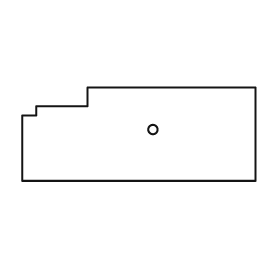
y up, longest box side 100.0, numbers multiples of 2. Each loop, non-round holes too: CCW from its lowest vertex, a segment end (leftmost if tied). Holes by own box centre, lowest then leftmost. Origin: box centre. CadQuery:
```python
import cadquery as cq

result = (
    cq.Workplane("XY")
    .moveTo(-50.0, -20.0)
    .lineTo(50.0, -20.0)
    .lineTo(50.0, 20.0)
    .lineTo(-22.0, 20.0)
    .lineTo(-22.0, 12.0)
    .lineTo(-44.0, 12.0)
    .lineTo(-44.0, 8.0)
    .lineTo(-50.0, 8.0)
    .close()
    .moveTo(6.0, 2.0)
    .circle(2.0)
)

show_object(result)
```